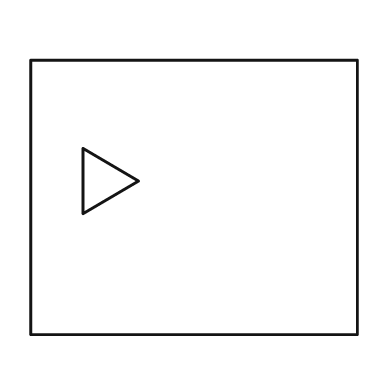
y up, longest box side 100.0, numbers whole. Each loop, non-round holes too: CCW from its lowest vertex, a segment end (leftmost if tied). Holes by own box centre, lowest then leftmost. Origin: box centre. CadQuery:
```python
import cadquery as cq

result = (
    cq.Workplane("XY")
    .moveTo(-50.0, -42.0)
    .lineTo(50.0, -42.0)
    .lineTo(50.0, 42.0)
    .lineTo(-50.0, 42.0)
    .close()
    .moveTo(-34.0, -5.0)
    .lineTo(-17.0, 5.0)
    .lineTo(-34.0, 15.0)
    .close()
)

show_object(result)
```